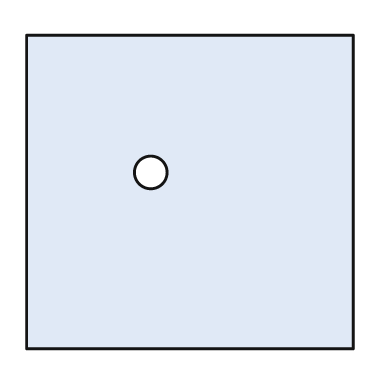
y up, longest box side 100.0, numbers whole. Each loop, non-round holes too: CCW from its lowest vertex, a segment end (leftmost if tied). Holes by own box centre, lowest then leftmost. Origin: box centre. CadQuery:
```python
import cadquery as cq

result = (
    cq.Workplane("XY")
    .moveTo(-50.0, -48.0)
    .lineTo(50.0, -48.0)
    .lineTo(50.0, 48.0)
    .lineTo(-50.0, 48.0)
    .close()
    .moveTo(-12.0, 6.0)
    .circle(5.0)
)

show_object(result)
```